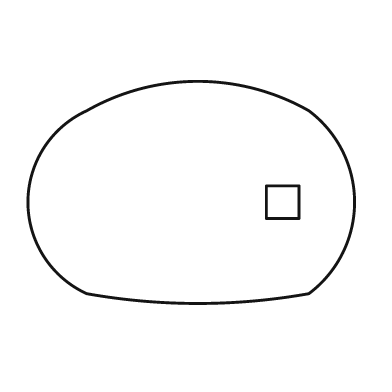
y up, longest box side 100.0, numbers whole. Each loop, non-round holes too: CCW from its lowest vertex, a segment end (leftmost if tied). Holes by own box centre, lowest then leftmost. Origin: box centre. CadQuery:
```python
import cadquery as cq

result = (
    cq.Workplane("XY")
    .moveTo(-32.0, -31.0)
    .threePointArc((2.0, -34.0), (36.0, -31.0))
    .threePointArc((50.0, -3.0), (36.0, 25.0))
    .threePointArc((2.0, 34.0), (-32.0, 25.0))
    .threePointArc((-50.0, -3.0), (-32.0, -31.0))
    .close()
    .moveTo(23.0, -8.0)
    .lineTo(33.0, -8.0)
    .lineTo(33.0, 2.0)
    .lineTo(23.0, 2.0)
    .close()
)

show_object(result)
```